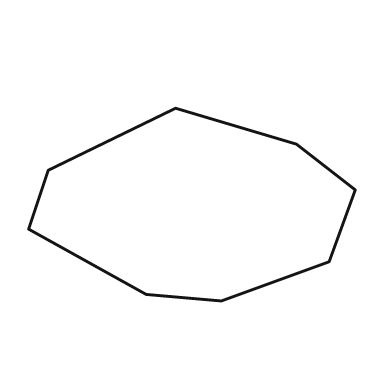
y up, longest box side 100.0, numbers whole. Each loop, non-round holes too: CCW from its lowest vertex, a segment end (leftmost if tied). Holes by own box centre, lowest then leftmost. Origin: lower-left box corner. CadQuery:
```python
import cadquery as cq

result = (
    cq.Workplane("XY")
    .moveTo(59.0, 0.0)
    .lineTo(92.0, 12.0)
    .lineTo(100.0, 34.0)
    .lineTo(82.0, 48.0)
    .lineTo(45.0, 59.0)
    .lineTo(6.0, 40.0)
    .lineTo(0.0, 22.0)
    .lineTo(36.0, 2.0)
    .close()
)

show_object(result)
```